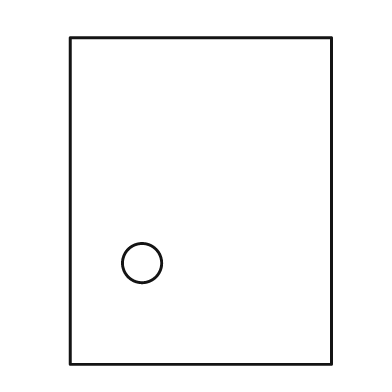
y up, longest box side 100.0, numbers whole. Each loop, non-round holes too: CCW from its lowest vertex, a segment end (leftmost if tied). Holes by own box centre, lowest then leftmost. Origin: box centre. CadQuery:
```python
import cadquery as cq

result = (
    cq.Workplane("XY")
    .moveTo(-40.0, -50.0)
    .lineTo(40.0, -50.0)
    .lineTo(40.0, 50.0)
    .lineTo(-40.0, 50.0)
    .close()
    .moveTo(-18.0, -19.0)
    .circle(6.0)
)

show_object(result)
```